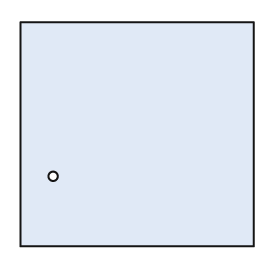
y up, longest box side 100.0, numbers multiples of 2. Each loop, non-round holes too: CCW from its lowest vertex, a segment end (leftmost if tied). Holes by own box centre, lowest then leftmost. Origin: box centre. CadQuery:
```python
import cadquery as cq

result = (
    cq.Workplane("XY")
    .moveTo(-50.0, -48.0)
    .lineTo(50.0, -48.0)
    .lineTo(50.0, 48.0)
    .lineTo(-50.0, 48.0)
    .close()
    .moveTo(-36.0, -18.0)
    .circle(2.0)
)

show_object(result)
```